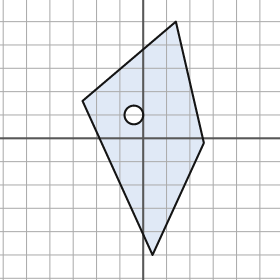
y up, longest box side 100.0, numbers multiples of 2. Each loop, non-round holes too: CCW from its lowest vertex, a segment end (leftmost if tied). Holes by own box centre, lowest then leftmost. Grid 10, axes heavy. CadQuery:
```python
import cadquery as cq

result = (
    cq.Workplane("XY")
    .moveTo(4.0, -50.0)
    .lineTo(26.0, -2.0)
    .lineTo(14.0, 50.0)
    .lineTo(-26.0, 16.0)
    .close()
    .moveTo(-4.0, 10.0)
    .circle(4.0)
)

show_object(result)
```